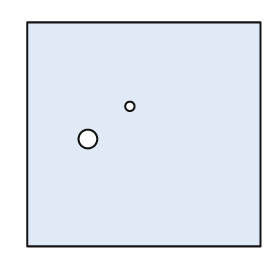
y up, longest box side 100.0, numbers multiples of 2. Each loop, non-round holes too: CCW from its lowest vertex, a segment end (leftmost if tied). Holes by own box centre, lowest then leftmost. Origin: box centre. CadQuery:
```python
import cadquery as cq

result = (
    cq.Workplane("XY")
    .moveTo(-50.0, -48.0)
    .lineTo(50.0, -48.0)
    .lineTo(50.0, 48.0)
    .lineTo(-50.0, 48.0)
    .close()
    .moveTo(-24.0, -2.0)
    .circle(4.0)
    .moveTo(-6.0, 12.0)
    .circle(2.0)
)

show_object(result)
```